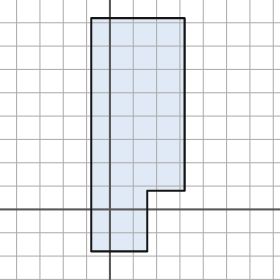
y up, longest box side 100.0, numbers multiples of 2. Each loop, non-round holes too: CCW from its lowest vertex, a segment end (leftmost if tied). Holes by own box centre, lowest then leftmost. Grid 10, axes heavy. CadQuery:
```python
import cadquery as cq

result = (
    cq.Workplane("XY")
    .moveTo(-8.0, -18.0)
    .lineTo(16.0, -18.0)
    .lineTo(16.0, 8.0)
    .lineTo(32.0, 8.0)
    .lineTo(32.0, 82.0)
    .lineTo(-8.0, 82.0)
    .close()
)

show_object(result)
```